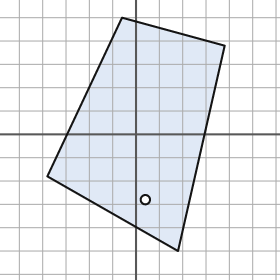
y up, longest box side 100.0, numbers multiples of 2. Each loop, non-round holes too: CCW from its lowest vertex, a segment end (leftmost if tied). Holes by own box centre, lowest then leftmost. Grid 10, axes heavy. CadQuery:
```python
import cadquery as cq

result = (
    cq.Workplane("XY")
    .moveTo(18.0, -50.0)
    .lineTo(38.0, 38.0)
    .lineTo(-6.0, 50.0)
    .lineTo(-38.0, -18.0)
    .close()
    .moveTo(4.0, -28.0)
    .circle(2.0)
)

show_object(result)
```